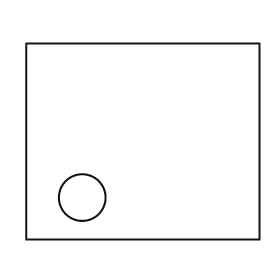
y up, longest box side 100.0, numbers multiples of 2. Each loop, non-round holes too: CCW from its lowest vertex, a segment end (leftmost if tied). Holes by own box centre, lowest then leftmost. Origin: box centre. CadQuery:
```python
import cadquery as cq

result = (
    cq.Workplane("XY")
    .moveTo(-50.0, -42.0)
    .lineTo(50.0, -42.0)
    .lineTo(50.0, 42.0)
    .lineTo(-50.0, 42.0)
    .close()
    .moveTo(-26.0, -24.0)
    .circle(10.0)
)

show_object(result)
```